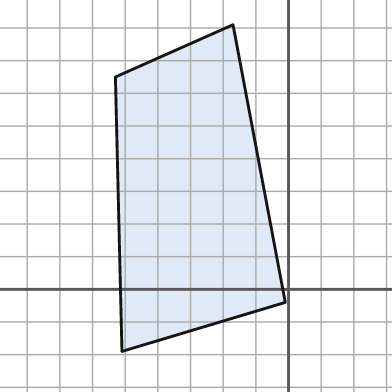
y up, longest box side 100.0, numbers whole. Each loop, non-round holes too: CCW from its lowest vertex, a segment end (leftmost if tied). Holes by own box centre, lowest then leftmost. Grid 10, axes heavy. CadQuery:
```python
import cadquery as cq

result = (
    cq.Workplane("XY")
    .moveTo(-51.0, -19.0)
    .lineTo(-1.0, -4.0)
    .lineTo(-17.0, 81.0)
    .lineTo(-53.0, 65.0)
    .close()
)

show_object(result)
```